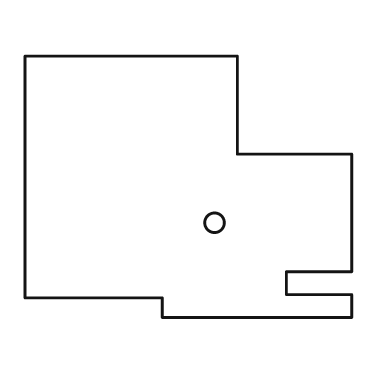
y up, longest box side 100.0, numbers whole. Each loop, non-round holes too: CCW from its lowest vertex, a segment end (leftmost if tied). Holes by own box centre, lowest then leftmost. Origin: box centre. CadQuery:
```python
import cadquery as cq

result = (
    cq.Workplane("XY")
    .moveTo(-8.0, -40.0)
    .lineTo(50.0, -40.0)
    .lineTo(50.0, -33.0)
    .lineTo(30.0, -33.0)
    .lineTo(30.0, -26.0)
    .lineTo(50.0, -26.0)
    .lineTo(50.0, 10.0)
    .lineTo(15.0, 10.0)
    .lineTo(15.0, 40.0)
    .lineTo(-50.0, 40.0)
    .lineTo(-50.0, -34.0)
    .lineTo(-8.0, -34.0)
    .close()
    .moveTo(8.0, -11.0)
    .circle(3.0)
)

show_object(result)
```